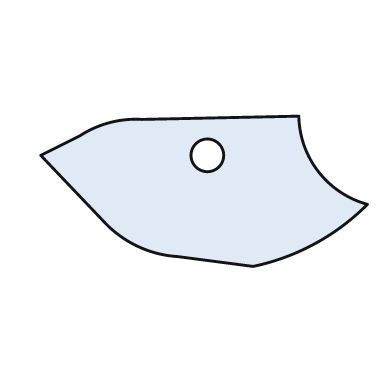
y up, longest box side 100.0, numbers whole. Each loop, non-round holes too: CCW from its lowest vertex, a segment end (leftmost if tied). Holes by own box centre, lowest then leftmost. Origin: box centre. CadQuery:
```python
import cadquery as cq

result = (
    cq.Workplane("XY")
    .moveTo(15.0, -23.0)
    .threePointArc((34.0, -16.0), (50.0, -4.0))
    .threePointArc((35.0, 6.0), (29.0, 23.0))
    .lineTo(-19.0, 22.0)
    .threePointArc((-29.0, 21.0), (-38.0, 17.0))
    .lineTo(-50.0, 11.0)
    .lineTo(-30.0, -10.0)
    .threePointArc((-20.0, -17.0), (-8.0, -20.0))
    .close()
    .moveTo(1.0, 11.0)
    .circle(5.0)
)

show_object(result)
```